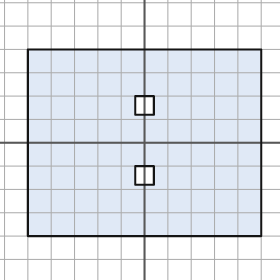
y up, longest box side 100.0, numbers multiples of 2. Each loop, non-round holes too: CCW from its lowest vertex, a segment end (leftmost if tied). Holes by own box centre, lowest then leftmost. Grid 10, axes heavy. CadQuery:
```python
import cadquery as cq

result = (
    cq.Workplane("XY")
    .moveTo(-50.0, -40.0)
    .lineTo(50.0, -40.0)
    .lineTo(50.0, 40.0)
    .lineTo(-50.0, 40.0)
    .close()
    .moveTo(-4.0, -18.0)
    .lineTo(4.0, -18.0)
    .lineTo(4.0, -10.0)
    .lineTo(-4.0, -10.0)
    .close()
    .moveTo(-4.0, 12.0)
    .lineTo(4.0, 12.0)
    .lineTo(4.0, 20.0)
    .lineTo(-4.0, 20.0)
    .close()
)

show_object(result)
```